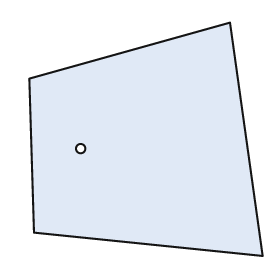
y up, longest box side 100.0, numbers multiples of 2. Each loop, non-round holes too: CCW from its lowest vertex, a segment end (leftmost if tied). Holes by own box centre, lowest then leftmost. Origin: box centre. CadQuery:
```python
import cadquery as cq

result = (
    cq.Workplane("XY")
    .moveTo(50.0, -50.0)
    .lineTo(36.0, 50.0)
    .lineTo(-50.0, 26.0)
    .lineTo(-48.0, -40.0)
    .close()
    .moveTo(-28.0, -4.0)
    .circle(2.0)
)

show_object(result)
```